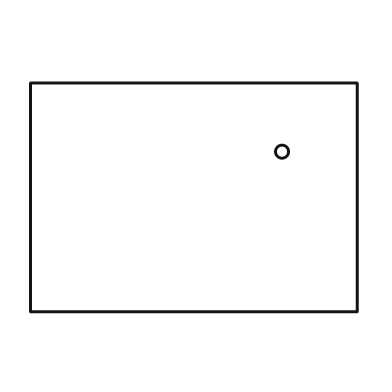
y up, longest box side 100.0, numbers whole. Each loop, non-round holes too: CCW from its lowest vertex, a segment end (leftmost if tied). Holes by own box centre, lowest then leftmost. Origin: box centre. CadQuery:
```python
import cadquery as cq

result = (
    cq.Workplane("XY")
    .moveTo(-50.0, -35.0)
    .lineTo(50.0, -35.0)
    .lineTo(50.0, 35.0)
    .lineTo(-50.0, 35.0)
    .close()
    .moveTo(27.0, 14.0)
    .circle(2.0)
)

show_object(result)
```